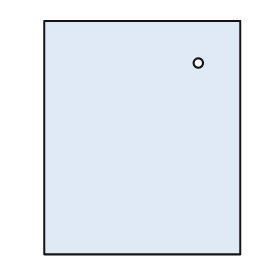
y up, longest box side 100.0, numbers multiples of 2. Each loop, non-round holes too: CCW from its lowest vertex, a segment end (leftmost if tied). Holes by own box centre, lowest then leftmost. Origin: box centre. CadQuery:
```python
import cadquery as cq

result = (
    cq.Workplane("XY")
    .moveTo(-42.0, -50.0)
    .lineTo(42.0, -50.0)
    .lineTo(42.0, 50.0)
    .lineTo(-42.0, 50.0)
    .close()
    .moveTo(24.0, 32.0)
    .circle(2.0)
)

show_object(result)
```